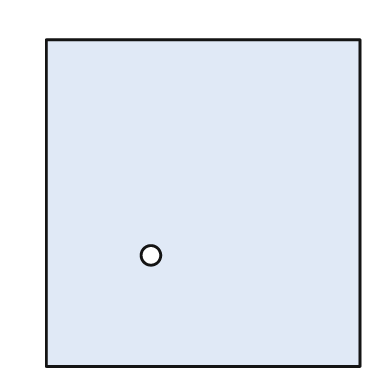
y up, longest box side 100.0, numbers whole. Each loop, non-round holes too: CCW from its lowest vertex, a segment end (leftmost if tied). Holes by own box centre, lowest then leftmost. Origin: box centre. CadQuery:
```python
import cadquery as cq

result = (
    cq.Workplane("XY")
    .moveTo(-48.0, -50.0)
    .lineTo(48.0, -50.0)
    .lineTo(48.0, 50.0)
    .lineTo(-48.0, 50.0)
    .close()
    .moveTo(-16.0, -16.0)
    .circle(3.0)
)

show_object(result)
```